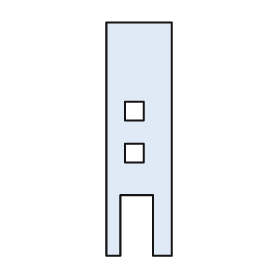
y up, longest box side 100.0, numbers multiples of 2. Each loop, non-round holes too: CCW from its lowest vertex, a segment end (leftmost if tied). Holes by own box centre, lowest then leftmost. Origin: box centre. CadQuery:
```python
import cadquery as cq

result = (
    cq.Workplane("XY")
    .moveTo(-14.0, -50.0)
    .lineTo(-8.0, -50.0)
    .lineTo(-8.0, -24.0)
    .lineTo(6.0, -24.0)
    .lineTo(6.0, -50.0)
    .lineTo(14.0, -50.0)
    .lineTo(14.0, 50.0)
    .lineTo(-14.0, 50.0)
    .close()
    .moveTo(-6.0, -10.0)
    .lineTo(2.0, -10.0)
    .lineTo(2.0, -2.0)
    .lineTo(-6.0, -2.0)
    .close()
    .moveTo(-6.0, 8.0)
    .lineTo(2.0, 8.0)
    .lineTo(2.0, 16.0)
    .lineTo(-6.0, 16.0)
    .close()
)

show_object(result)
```